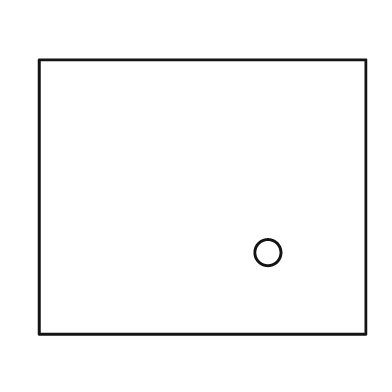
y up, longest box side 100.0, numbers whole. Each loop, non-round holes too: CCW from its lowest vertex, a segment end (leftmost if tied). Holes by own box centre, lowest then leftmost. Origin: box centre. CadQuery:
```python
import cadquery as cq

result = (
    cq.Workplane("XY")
    .moveTo(-50.0, -42.0)
    .lineTo(50.0, -42.0)
    .lineTo(50.0, 42.0)
    .lineTo(-50.0, 42.0)
    .close()
    .moveTo(20.0, -17.0)
    .circle(4.0)
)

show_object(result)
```